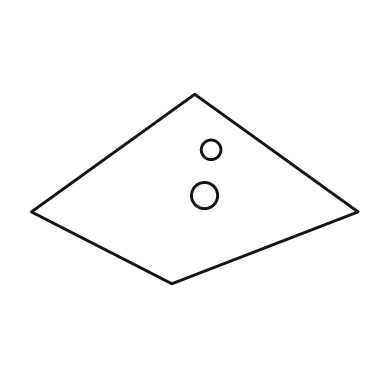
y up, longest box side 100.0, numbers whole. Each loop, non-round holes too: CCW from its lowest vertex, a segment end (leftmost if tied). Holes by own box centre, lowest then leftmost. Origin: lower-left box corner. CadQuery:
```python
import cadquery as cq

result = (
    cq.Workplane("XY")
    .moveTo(43.0, 0.0)
    .lineTo(100.0, 22.0)
    .lineTo(50.0, 58.0)
    .lineTo(0.0, 22.0)
    .close()
    .moveTo(53.0, 27.0)
    .circle(4.0)
    .moveTo(55.0, 41.0)
    .circle(3.0)
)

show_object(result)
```